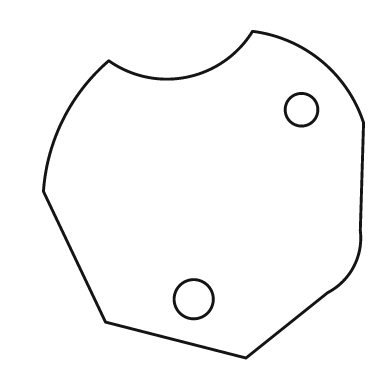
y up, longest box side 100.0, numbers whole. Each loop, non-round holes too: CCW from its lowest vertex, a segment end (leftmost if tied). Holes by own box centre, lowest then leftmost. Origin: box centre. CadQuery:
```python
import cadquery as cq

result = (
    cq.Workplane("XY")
    .moveTo(13.0, -50.0)
    .lineTo(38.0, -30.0)
    .threePointArc((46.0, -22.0), (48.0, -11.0))
    .lineTo(49.0, 22.0)
    .threePointArc((36.0, 41.0), (15.0, 50.0))
    .threePointArc((-5.0, 36.0), (-29.0, 41.0))
    .threePointArc((-43.0, 23.0), (-49.0, 1.0))
    .lineTo(-30.0, -39.0)
    .close()
    .moveTo(-3.0, -32.0)
    .circle(6.0)
    .moveTo(30.0, 26.0)
    .circle(5.0)
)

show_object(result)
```